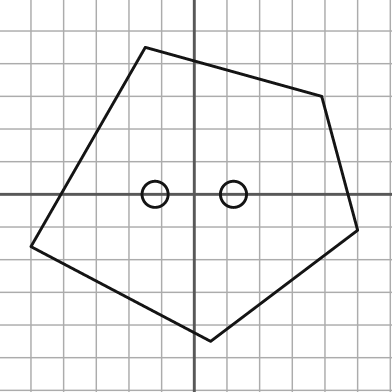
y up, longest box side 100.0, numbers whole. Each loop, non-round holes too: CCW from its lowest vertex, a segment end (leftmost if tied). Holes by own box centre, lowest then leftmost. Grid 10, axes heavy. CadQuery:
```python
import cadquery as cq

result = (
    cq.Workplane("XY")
    .moveTo(5.0, -45.0)
    .lineTo(50.0, -11.0)
    .lineTo(39.0, 30.0)
    .lineTo(-15.0, 45.0)
    .lineTo(-50.0, -16.0)
    .close()
    .moveTo(-12.0, 0.0)
    .circle(4.0)
    .moveTo(12.0, 0.0)
    .circle(4.0)
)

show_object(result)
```